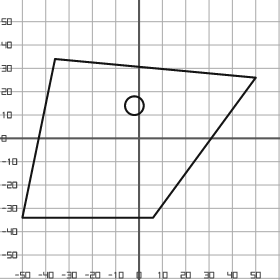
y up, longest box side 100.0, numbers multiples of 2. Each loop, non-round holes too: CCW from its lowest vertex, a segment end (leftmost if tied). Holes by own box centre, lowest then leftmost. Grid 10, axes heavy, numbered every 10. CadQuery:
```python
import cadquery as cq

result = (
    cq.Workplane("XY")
    .moveTo(-50.0, -34.0)
    .lineTo(6.0, -34.0)
    .lineTo(50.0, 26.0)
    .lineTo(-36.0, 34.0)
    .close()
    .moveTo(-2.0, 14.0)
    .circle(4.0)
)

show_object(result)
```